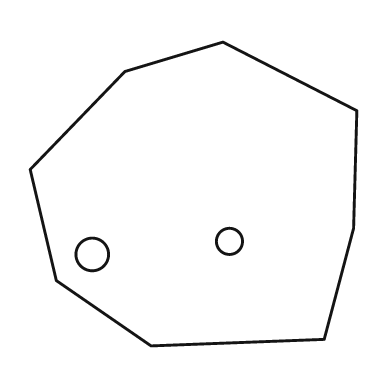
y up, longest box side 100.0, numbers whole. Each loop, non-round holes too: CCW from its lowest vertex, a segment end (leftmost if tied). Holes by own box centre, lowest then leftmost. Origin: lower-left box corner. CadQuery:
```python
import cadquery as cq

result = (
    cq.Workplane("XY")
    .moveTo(37.0, 0.0)
    .lineTo(90.0, 2.0)
    .lineTo(99.0, 36.0)
    .lineTo(100.0, 72.0)
    .lineTo(59.0, 93.0)
    .lineTo(29.0, 84.0)
    .lineTo(0.0, 54.0)
    .lineTo(8.0, 20.0)
    .close()
    .moveTo(19.0, 28.0)
    .circle(5.0)
    .moveTo(61.0, 32.0)
    .circle(4.0)
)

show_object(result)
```